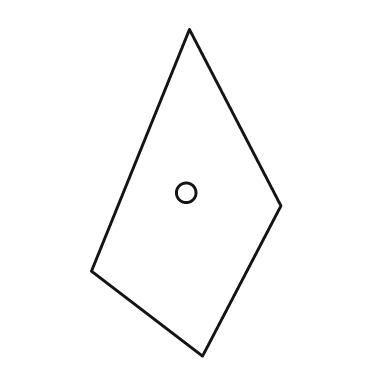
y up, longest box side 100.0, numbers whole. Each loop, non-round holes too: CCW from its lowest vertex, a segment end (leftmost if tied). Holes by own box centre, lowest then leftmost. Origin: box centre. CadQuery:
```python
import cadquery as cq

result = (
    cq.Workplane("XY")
    .moveTo(5.0, -50.0)
    .lineTo(29.0, -4.0)
    .lineTo(1.0, 50.0)
    .lineTo(-29.0, -24.0)
    .close()
    .moveTo(0.0, 0.0)
    .circle(3.0)
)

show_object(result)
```